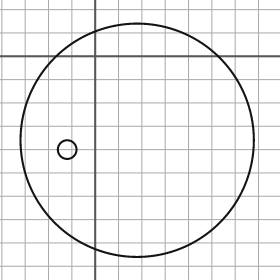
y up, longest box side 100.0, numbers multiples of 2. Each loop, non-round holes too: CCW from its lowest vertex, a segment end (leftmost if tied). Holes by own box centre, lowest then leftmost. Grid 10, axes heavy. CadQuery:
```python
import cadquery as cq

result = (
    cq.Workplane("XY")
    .moveTo(18.0, -36.0)
    .circle(50.0)
    .moveTo(-12.0, -40.0)
    .circle(4.0)
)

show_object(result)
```